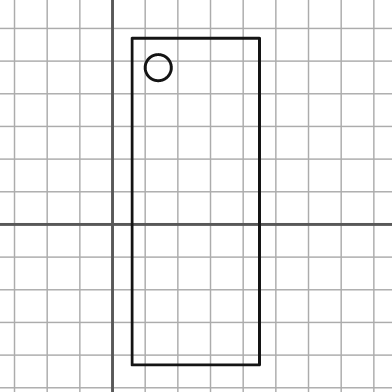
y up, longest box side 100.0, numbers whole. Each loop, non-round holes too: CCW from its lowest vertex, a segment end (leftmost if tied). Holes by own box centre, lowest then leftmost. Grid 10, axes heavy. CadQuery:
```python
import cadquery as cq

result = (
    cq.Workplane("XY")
    .moveTo(6.0, -43.0)
    .lineTo(45.0, -43.0)
    .lineTo(45.0, 57.0)
    .lineTo(6.0, 57.0)
    .close()
    .moveTo(14.0, 48.0)
    .circle(4.0)
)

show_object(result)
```